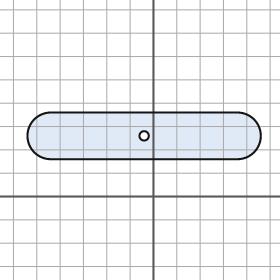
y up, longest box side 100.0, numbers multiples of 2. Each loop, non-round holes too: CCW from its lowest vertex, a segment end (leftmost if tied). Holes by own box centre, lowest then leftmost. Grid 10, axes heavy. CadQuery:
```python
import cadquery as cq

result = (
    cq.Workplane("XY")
    .moveTo(-44.0, 16.0)
    .lineTo(36.0, 16.0)
    .threePointArc((46.0, 26.0), (36.0, 36.0))
    .lineTo(-44.0, 36.0)
    .threePointArc((-54.0, 26.0), (-44.0, 16.0))
    .close()
    .moveTo(-4.0, 26.0)
    .circle(2.0)
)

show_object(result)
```